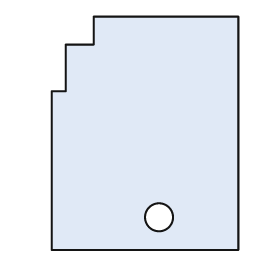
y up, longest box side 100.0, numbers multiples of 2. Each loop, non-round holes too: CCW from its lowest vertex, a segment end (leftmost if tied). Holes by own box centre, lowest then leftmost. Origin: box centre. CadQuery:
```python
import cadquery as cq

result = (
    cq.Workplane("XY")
    .moveTo(-40.0, -50.0)
    .lineTo(40.0, -50.0)
    .lineTo(40.0, 50.0)
    .lineTo(-22.0, 50.0)
    .lineTo(-22.0, 38.0)
    .lineTo(-34.0, 38.0)
    .lineTo(-34.0, 18.0)
    .lineTo(-40.0, 18.0)
    .close()
    .moveTo(6.0, -36.0)
    .circle(6.0)
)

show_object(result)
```